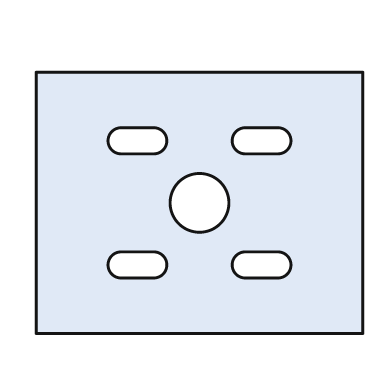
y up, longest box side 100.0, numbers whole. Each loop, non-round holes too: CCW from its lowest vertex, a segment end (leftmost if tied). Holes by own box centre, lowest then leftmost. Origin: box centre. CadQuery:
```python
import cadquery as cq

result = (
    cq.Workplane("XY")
    .moveTo(-50.0, -40.0)
    .lineTo(50.0, -40.0)
    .lineTo(50.0, 40.0)
    .lineTo(-50.0, 40.0)
    .close()
    .moveTo(-24.0, -23.0)
    .lineTo(-14.0, -23.0)
    .threePointArc((-10.0, -19.0), (-14.0, -15.0))
    .lineTo(-24.0, -15.0)
    .threePointArc((-28.0, -19.0), (-24.0, -23.0))
    .close()
    .moveTo(14.0, -23.0)
    .lineTo(24.0, -23.0)
    .threePointArc((28.0, -19.0), (24.0, -15.0))
    .lineTo(14.0, -15.0)
    .threePointArc((10.0, -19.0), (14.0, -23.0))
    .close()
    .moveTo(0.0, 0.0)
    .circle(9.0)
    .moveTo(-24.0, 15.0)
    .lineTo(-14.0, 15.0)
    .threePointArc((-10.0, 19.0), (-14.0, 23.0))
    .lineTo(-24.0, 23.0)
    .threePointArc((-28.0, 19.0), (-24.0, 15.0))
    .close()
    .moveTo(14.0, 15.0)
    .lineTo(24.0, 15.0)
    .threePointArc((28.0, 19.0), (24.0, 23.0))
    .lineTo(14.0, 23.0)
    .threePointArc((10.0, 19.0), (14.0, 15.0))
    .close()
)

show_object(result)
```